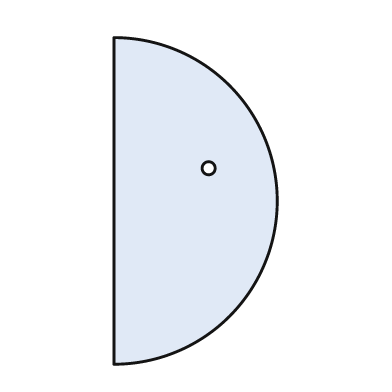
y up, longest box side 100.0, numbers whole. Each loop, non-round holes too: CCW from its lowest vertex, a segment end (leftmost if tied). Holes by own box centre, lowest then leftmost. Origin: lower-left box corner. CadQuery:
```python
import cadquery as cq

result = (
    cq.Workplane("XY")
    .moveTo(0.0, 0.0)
    .threePointArc((50.0, 50.0), (0.0, 100.0))
    .close()
    .moveTo(29.0, 60.0)
    .circle(2.0)
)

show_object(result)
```